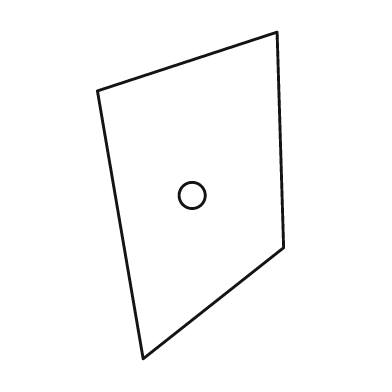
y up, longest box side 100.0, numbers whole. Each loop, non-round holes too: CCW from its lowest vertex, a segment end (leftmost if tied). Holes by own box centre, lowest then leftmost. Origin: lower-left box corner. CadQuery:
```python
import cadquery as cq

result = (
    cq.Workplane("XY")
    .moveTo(14.0, 0.0)
    .lineTo(57.0, 34.0)
    .lineTo(55.0, 100.0)
    .lineTo(0.0, 82.0)
    .close()
    .moveTo(29.0, 50.0)
    .circle(4.0)
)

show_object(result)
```